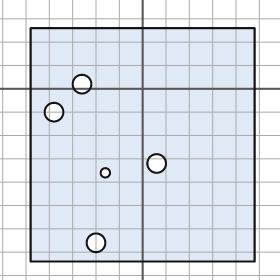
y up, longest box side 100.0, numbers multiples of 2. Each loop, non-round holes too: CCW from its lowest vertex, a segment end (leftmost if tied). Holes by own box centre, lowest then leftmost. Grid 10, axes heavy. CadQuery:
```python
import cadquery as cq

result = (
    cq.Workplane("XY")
    .moveTo(-48.0, -74.0)
    .lineTo(48.0, -74.0)
    .lineTo(48.0, 26.0)
    .lineTo(-48.0, 26.0)
    .close()
    .moveTo(-20.0, -66.0)
    .circle(4.0)
    .moveTo(-16.0, -36.0)
    .circle(2.0)
    .moveTo(6.0, -32.0)
    .circle(4.0)
    .moveTo(-38.0, -10.0)
    .circle(4.0)
    .moveTo(-26.0, 2.0)
    .circle(4.0)
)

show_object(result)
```